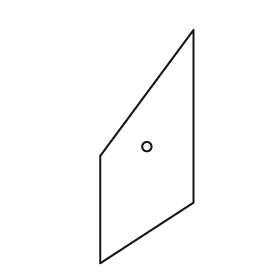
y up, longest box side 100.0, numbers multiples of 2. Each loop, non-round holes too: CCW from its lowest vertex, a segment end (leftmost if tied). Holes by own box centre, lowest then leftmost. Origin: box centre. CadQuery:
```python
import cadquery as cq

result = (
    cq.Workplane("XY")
    .moveTo(-20.0, -50.0)
    .lineTo(20.0, -24.0)
    .lineTo(20.0, 50.0)
    .lineTo(-20.0, -4.0)
    .close()
    .moveTo(0.0, 0.0)
    .circle(2.0)
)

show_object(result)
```